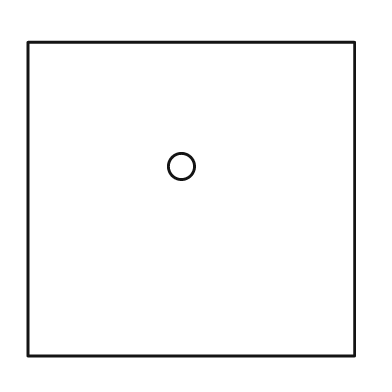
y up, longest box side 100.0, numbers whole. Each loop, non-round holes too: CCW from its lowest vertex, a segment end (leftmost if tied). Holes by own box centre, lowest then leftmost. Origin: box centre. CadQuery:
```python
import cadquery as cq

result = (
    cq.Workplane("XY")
    .moveTo(-50.0, -48.0)
    .lineTo(50.0, -48.0)
    .lineTo(50.0, 48.0)
    .lineTo(-50.0, 48.0)
    .close()
    .moveTo(-3.0, 10.0)
    .circle(4.0)
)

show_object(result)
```